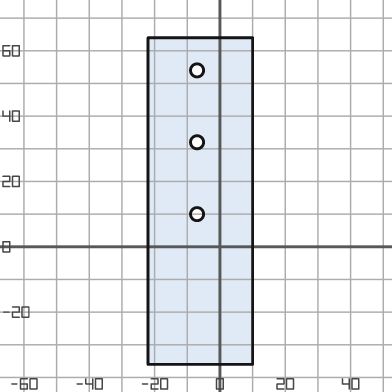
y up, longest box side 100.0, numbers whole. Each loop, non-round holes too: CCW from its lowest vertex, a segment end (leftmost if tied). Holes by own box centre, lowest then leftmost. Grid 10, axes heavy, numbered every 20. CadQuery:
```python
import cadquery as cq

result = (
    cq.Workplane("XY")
    .moveTo(-22.0, -36.0)
    .lineTo(10.0, -36.0)
    .lineTo(10.0, 64.0)
    .lineTo(-22.0, 64.0)
    .close()
    .moveTo(-7.0, 10.0)
    .circle(2.0)
    .moveTo(-7.0, 32.0)
    .circle(2.0)
    .moveTo(-7.0, 54.0)
    .circle(2.0)
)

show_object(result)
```